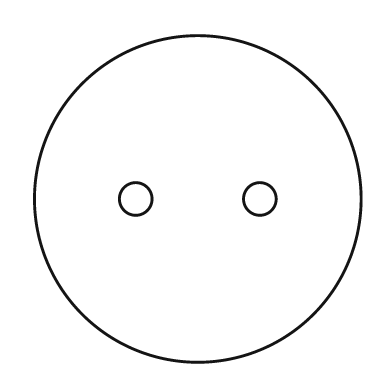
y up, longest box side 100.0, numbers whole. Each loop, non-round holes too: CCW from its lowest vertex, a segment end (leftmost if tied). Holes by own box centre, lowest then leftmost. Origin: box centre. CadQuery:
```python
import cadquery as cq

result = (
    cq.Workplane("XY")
    .moveTo(0.0, 0.0)
    .circle(50.0)
    .moveTo(-19.0, 0.0)
    .circle(5.0)
    .moveTo(19.0, 0.0)
    .circle(5.0)
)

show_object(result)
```